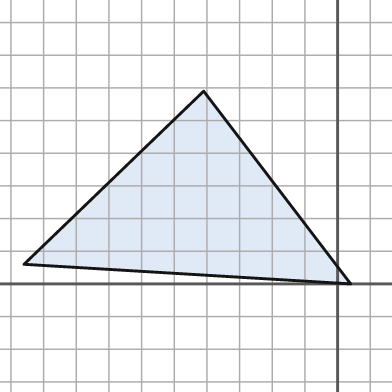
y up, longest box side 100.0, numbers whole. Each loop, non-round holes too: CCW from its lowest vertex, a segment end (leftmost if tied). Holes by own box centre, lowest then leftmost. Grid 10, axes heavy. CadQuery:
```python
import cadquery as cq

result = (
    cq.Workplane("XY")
    .moveTo(4.0, 0.0)
    .lineTo(-41.0, 59.0)
    .lineTo(-96.0, 6.0)
    .close()
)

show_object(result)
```